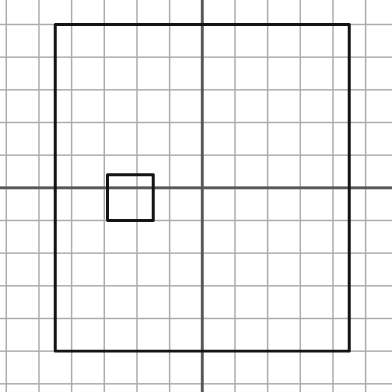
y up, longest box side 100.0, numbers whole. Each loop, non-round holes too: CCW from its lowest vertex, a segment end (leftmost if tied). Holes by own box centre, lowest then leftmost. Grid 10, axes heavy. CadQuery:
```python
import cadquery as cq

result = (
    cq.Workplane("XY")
    .moveTo(-45.0, -50.0)
    .lineTo(45.0, -50.0)
    .lineTo(45.0, 50.0)
    .lineTo(-45.0, 50.0)
    .close()
    .moveTo(-29.0, -10.0)
    .lineTo(-15.0, -10.0)
    .lineTo(-15.0, 4.0)
    .lineTo(-29.0, 4.0)
    .close()
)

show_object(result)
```